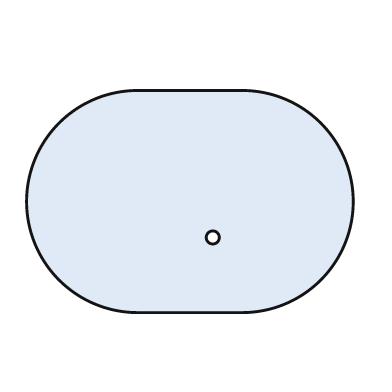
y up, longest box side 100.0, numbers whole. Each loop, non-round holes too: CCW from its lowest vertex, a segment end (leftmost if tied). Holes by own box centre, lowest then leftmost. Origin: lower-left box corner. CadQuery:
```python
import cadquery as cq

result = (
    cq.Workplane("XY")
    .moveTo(34.0, 0.0)
    .lineTo(66.0, 0.0)
    .threePointArc((100.0, 34.0), (66.0, 68.0))
    .lineTo(34.0, 68.0)
    .threePointArc((0.0, 34.0), (34.0, 0.0))
    .close()
    .moveTo(57.0, 23.0)
    .circle(2.0)
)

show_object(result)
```